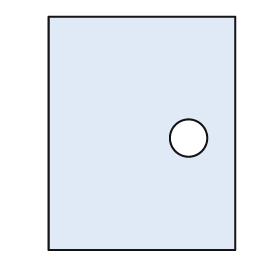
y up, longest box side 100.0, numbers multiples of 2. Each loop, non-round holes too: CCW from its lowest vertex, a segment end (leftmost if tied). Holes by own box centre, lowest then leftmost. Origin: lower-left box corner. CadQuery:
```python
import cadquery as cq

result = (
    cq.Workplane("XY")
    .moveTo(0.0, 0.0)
    .lineTo(80.0, 0.0)
    .lineTo(80.0, 100.0)
    .lineTo(0.0, 100.0)
    .close()
    .moveTo(60.0, 48.0)
    .circle(8.0)
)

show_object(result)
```